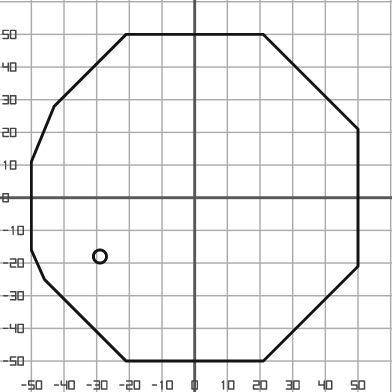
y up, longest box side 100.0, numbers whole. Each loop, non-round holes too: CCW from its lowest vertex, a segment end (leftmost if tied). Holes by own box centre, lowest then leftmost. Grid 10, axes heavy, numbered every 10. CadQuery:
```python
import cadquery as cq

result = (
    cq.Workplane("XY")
    .moveTo(-21.0, -50.0)
    .lineTo(21.0, -50.0)
    .lineTo(50.0, -21.0)
    .lineTo(50.0, 21.0)
    .lineTo(21.0, 50.0)
    .lineTo(-21.0, 50.0)
    .lineTo(-43.0, 28.0)
    .lineTo(-50.0, 11.0)
    .lineTo(-50.0, -16.0)
    .lineTo(-46.0, -25.0)
    .close()
    .moveTo(-29.0, -18.0)
    .circle(2.0)
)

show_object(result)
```